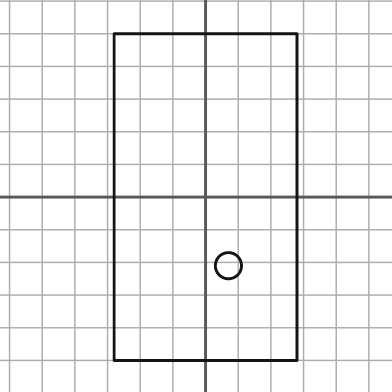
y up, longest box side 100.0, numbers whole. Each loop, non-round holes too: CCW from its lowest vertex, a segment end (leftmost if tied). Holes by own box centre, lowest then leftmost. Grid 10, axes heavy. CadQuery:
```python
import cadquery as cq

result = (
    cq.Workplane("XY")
    .moveTo(-28.0, -50.0)
    .lineTo(28.0, -50.0)
    .lineTo(28.0, 50.0)
    .lineTo(-28.0, 50.0)
    .close()
    .moveTo(7.0, -21.0)
    .circle(4.0)
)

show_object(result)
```